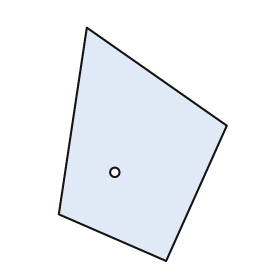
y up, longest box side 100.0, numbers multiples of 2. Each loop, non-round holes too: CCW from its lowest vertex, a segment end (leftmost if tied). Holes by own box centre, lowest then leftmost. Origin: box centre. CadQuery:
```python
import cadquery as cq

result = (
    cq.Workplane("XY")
    .moveTo(10.0, -50.0)
    .lineTo(36.0, 8.0)
    .lineTo(-24.0, 50.0)
    .lineTo(-36.0, -30.0)
    .close()
    .moveTo(-12.0, -12.0)
    .circle(2.0)
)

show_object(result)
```